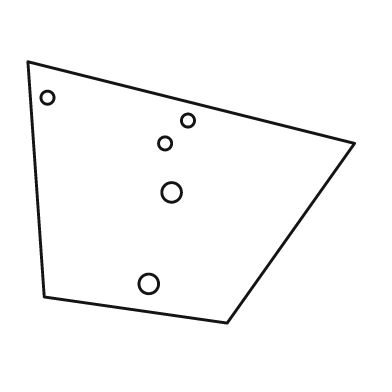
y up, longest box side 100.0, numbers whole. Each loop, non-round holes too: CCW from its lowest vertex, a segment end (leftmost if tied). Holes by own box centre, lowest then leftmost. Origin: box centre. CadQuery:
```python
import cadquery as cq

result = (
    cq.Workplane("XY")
    .moveTo(11.0, -40.0)
    .lineTo(50.0, 15.0)
    .lineTo(-50.0, 40.0)
    .lineTo(-45.0, -32.0)
    .close()
    .moveTo(-13.0, -28.0)
    .circle(3.0)
    .moveTo(-6.0, 0.0)
    .circle(3.0)
    .moveTo(-8.0, 15.0)
    .circle(2.0)
    .moveTo(-1.0, 22.0)
    .circle(2.0)
    .moveTo(-44.0, 29.0)
    .circle(2.0)
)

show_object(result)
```